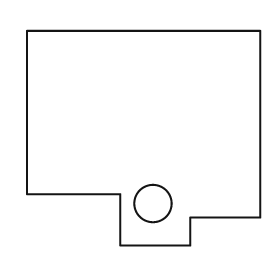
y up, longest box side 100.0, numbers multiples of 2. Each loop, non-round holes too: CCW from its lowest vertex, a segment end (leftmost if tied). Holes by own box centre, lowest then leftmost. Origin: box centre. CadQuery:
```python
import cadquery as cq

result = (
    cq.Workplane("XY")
    .moveTo(-10.0, -46.0)
    .lineTo(20.0, -46.0)
    .lineTo(20.0, -34.0)
    .lineTo(50.0, -34.0)
    .lineTo(50.0, 46.0)
    .lineTo(-50.0, 46.0)
    .lineTo(-50.0, -24.0)
    .lineTo(-10.0, -24.0)
    .close()
    .moveTo(4.0, -28.0)
    .circle(8.0)
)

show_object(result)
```